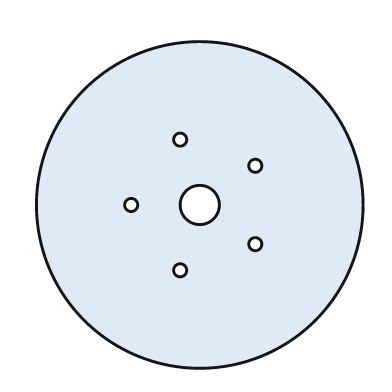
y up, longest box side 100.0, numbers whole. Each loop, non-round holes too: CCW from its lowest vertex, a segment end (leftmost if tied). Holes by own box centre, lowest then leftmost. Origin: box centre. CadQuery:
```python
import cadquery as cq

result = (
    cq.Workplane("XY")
    .moveTo(0.0, 0.0)
    .circle(50.0)
    .moveTo(-6.0, -20.0)
    .circle(2.0)
    .moveTo(17.0, -12.0)
    .circle(2.0)
    .moveTo(-21.0, 0.0)
    .circle(2.0)
    .moveTo(0.0, 0.0)
    .circle(6.0)
    .moveTo(17.0, 12.0)
    .circle(2.0)
    .moveTo(-6.0, 20.0)
    .circle(2.0)
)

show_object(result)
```